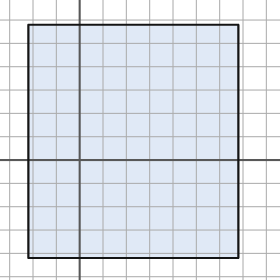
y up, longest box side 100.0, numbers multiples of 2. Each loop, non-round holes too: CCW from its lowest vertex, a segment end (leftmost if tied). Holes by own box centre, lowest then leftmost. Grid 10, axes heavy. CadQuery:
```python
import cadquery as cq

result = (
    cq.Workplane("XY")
    .moveTo(-22.0, -42.0)
    .lineTo(68.0, -42.0)
    .lineTo(68.0, 58.0)
    .lineTo(-22.0, 58.0)
    .close()
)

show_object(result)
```